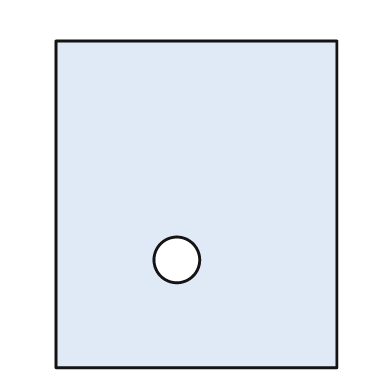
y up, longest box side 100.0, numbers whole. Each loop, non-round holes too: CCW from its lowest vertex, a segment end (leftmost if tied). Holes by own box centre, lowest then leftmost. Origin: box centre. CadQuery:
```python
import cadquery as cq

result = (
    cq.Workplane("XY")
    .moveTo(-43.0, -50.0)
    .lineTo(43.0, -50.0)
    .lineTo(43.0, 50.0)
    .lineTo(-43.0, 50.0)
    .close()
    .moveTo(-6.0, -17.0)
    .circle(7.0)
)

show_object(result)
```